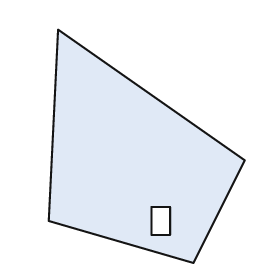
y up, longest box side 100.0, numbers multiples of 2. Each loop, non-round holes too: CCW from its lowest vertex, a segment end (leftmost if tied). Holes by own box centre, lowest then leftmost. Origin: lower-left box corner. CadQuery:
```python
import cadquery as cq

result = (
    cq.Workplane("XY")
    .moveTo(62.0, 0.0)
    .lineTo(84.0, 44.0)
    .lineTo(4.0, 100.0)
    .lineTo(0.0, 18.0)
    .close()
    .moveTo(44.0, 12.0)
    .lineTo(52.0, 12.0)
    .lineTo(52.0, 24.0)
    .lineTo(44.0, 24.0)
    .close()
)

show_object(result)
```